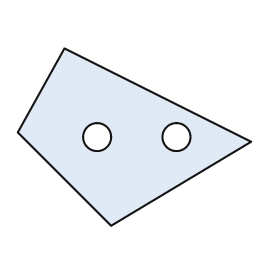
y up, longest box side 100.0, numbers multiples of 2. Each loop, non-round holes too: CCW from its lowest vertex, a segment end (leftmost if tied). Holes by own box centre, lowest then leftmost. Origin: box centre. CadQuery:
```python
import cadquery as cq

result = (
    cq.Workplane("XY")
    .moveTo(-10.0, -38.0)
    .lineTo(50.0, -2.0)
    .lineTo(-30.0, 38.0)
    .lineTo(-50.0, 2.0)
    .close()
    .moveTo(-16.0, 0.0)
    .circle(6.0)
    .moveTo(18.0, 0.0)
    .circle(6.0)
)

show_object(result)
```